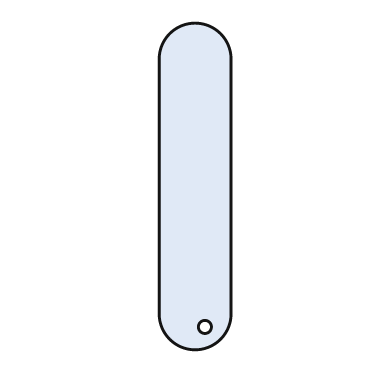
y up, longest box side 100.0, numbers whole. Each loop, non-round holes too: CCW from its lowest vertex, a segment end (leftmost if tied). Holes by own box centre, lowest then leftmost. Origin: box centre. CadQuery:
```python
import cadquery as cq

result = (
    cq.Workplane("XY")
    .moveTo(-11.0, -39.0)
    .threePointArc((0.0, -50.0), (11.0, -39.0))
    .lineTo(11.0, 39.0)
    .threePointArc((0.0, 50.0), (-11.0, 39.0))
    .close()
    .moveTo(3.0, -43.0)
    .circle(2.0)
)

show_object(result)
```